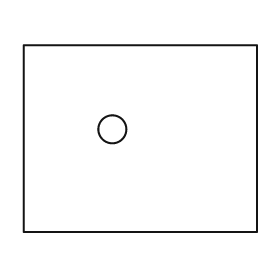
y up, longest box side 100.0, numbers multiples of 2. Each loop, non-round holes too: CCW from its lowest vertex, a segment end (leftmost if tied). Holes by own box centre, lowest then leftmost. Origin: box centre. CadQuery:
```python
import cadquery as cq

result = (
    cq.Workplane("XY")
    .moveTo(-50.0, -40.0)
    .lineTo(50.0, -40.0)
    .lineTo(50.0, 40.0)
    .lineTo(-50.0, 40.0)
    .close()
    .moveTo(-12.0, 4.0)
    .circle(6.0)
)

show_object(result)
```